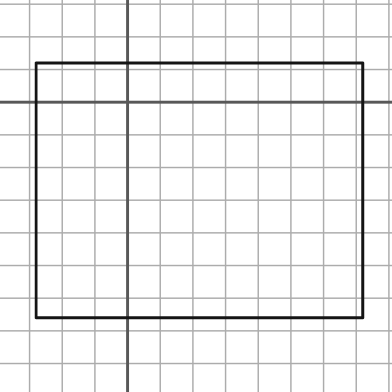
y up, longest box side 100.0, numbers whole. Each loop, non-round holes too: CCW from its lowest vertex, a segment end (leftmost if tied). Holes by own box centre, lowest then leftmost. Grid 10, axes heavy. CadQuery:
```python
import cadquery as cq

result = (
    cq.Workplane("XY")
    .moveTo(-28.0, -66.0)
    .lineTo(72.0, -66.0)
    .lineTo(72.0, 12.0)
    .lineTo(-28.0, 12.0)
    .close()
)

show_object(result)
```